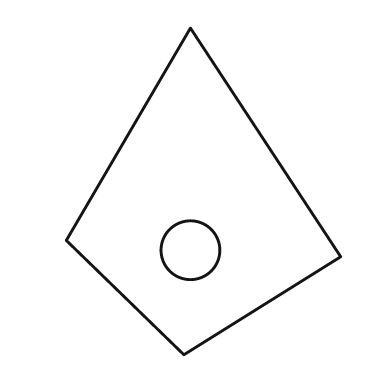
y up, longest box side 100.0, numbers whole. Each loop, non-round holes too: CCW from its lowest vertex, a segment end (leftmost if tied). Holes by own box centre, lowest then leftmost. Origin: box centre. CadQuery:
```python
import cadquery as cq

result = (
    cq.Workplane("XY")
    .moveTo(-6.0, -50.0)
    .lineTo(42.0, -20.0)
    .lineTo(-4.0, 50.0)
    .lineTo(-42.0, -15.0)
    .close()
    .moveTo(-4.0, -18.0)
    .circle(9.0)
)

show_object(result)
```